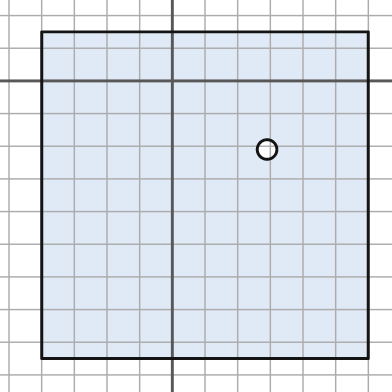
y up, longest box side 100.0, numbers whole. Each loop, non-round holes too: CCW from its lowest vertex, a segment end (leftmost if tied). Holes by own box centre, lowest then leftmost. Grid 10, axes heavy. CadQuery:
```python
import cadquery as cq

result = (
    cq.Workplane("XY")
    .moveTo(-40.0, -85.0)
    .lineTo(60.0, -85.0)
    .lineTo(60.0, 15.0)
    .lineTo(-40.0, 15.0)
    .close()
    .moveTo(29.0, -21.0)
    .circle(3.0)
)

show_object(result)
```